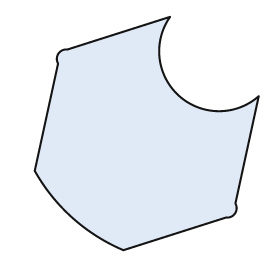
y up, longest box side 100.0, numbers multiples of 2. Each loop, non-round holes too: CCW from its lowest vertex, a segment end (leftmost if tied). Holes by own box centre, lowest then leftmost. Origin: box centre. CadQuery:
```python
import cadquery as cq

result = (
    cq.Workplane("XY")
    .moveTo(-10.0, -50.0)
    .lineTo(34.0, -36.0)
    .threePointArc((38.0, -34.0), (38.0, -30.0))
    .lineTo(48.0, 16.0)
    .threePointArc((14.0, 16.0), (10.0, 50.0))
    .lineTo(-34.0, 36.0)
    .threePointArc((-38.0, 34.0), (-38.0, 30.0))
    .lineTo(-48.0, -16.0)
    .threePointArc((-32.0, -36.0), (-10.0, -50.0))
    .close()
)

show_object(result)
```